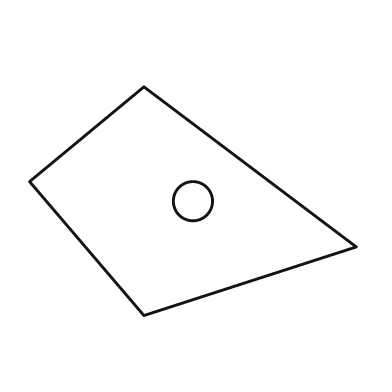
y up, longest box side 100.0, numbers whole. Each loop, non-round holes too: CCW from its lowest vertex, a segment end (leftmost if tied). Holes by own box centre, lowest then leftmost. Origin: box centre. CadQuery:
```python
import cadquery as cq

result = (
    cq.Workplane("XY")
    .moveTo(-15.0, -35.0)
    .lineTo(50.0, -14.0)
    .lineTo(-15.0, 35.0)
    .lineTo(-50.0, 6.0)
    .close()
    .moveTo(0.0, 0.0)
    .circle(6.0)
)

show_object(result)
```